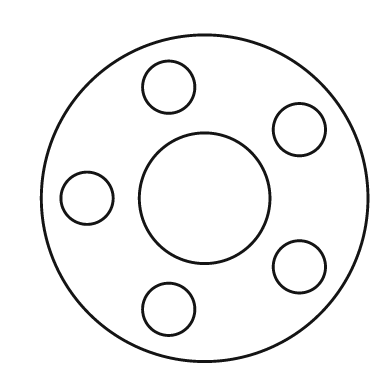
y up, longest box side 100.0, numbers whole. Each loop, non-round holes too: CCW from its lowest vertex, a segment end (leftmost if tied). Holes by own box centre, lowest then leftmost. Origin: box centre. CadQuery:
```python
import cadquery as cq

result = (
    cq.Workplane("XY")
    .moveTo(0.0, 0.0)
    .circle(50.0)
    .moveTo(-11.0, -34.0)
    .circle(8.0)
    .moveTo(29.0, -21.0)
    .circle(8.0)
    .moveTo(-36.0, 0.0)
    .circle(8.0)
    .moveTo(0.0, 0.0)
    .circle(20.0)
    .moveTo(29.0, 21.0)
    .circle(8.0)
    .moveTo(-11.0, 34.0)
    .circle(8.0)
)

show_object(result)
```